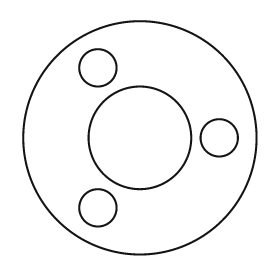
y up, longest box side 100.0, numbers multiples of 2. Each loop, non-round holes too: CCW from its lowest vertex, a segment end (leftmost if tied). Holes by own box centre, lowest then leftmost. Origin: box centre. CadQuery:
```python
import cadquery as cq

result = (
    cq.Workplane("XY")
    .moveTo(0.0, 0.0)
    .circle(50.0)
    .moveTo(-18.0, -30.0)
    .circle(8.0)
    .moveTo(0.0, 0.0)
    .circle(22.0)
    .moveTo(34.0, 0.0)
    .circle(8.0)
    .moveTo(-18.0, 30.0)
    .circle(8.0)
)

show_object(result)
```